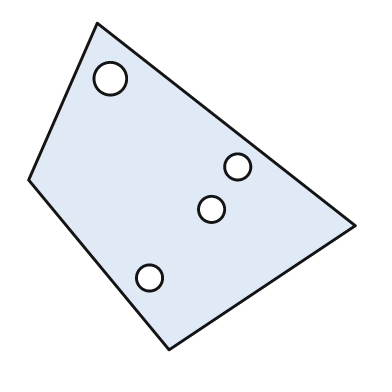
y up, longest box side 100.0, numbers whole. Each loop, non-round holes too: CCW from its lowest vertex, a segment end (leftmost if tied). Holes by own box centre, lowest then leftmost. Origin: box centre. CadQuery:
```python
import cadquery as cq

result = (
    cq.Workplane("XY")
    .moveTo(-7.0, -50.0)
    .lineTo(50.0, -12.0)
    .lineTo(-29.0, 50.0)
    .lineTo(-50.0, 2.0)
    .close()
    .moveTo(-13.0, -28.0)
    .circle(4.0)
    .moveTo(6.0, -7.0)
    .circle(4.0)
    .moveTo(14.0, 6.0)
    .circle(4.0)
    .moveTo(-25.0, 33.0)
    .circle(5.0)
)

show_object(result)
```